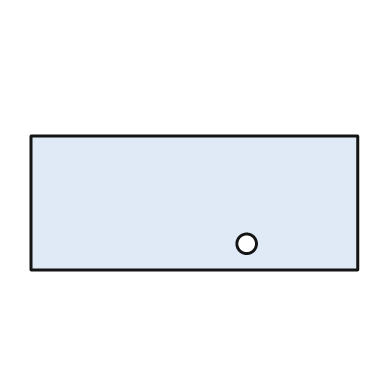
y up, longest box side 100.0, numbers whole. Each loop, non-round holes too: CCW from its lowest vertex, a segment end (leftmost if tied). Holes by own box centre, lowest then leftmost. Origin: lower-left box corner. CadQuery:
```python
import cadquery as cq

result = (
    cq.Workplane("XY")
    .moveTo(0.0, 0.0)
    .lineTo(100.0, 0.0)
    .lineTo(100.0, 41.0)
    .lineTo(0.0, 41.0)
    .close()
    .moveTo(66.0, 8.0)
    .circle(3.0)
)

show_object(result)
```